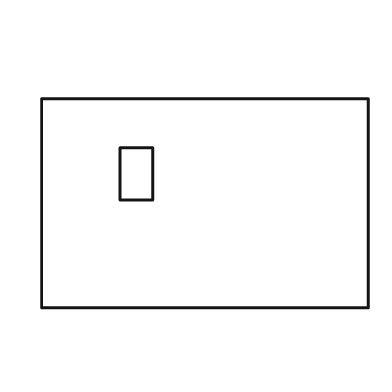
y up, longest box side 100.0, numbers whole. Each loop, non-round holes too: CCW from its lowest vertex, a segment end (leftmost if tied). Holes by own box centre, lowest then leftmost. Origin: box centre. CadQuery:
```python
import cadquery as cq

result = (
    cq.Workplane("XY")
    .moveTo(-50.0, -32.0)
    .lineTo(50.0, -32.0)
    .lineTo(50.0, 32.0)
    .lineTo(-50.0, 32.0)
    .close()
    .moveTo(-26.0, 1.0)
    .lineTo(-16.0, 1.0)
    .lineTo(-16.0, 17.0)
    .lineTo(-26.0, 17.0)
    .close()
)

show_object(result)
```